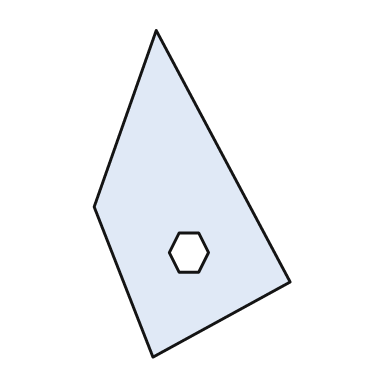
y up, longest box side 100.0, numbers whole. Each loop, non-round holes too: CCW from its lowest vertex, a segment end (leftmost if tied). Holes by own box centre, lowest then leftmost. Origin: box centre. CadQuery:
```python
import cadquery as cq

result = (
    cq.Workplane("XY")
    .moveTo(-12.0, -50.0)
    .lineTo(30.0, -27.0)
    .lineTo(-11.0, 50.0)
    .lineTo(-30.0, -4.0)
    .close()
    .moveTo(-4.0, -24.0)
    .lineTo(2.0, -24.0)
    .lineTo(5.0, -18.0)
    .lineTo(2.0, -12.0)
    .lineTo(-4.0, -12.0)
    .lineTo(-7.0, -18.0)
    .close()
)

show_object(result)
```